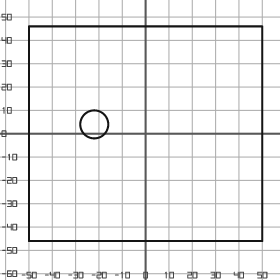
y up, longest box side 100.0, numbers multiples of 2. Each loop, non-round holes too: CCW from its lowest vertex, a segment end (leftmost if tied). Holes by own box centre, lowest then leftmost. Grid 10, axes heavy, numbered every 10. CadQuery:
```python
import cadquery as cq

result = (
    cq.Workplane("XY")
    .moveTo(-50.0, -46.0)
    .lineTo(50.0, -46.0)
    .lineTo(50.0, 46.0)
    .lineTo(-50.0, 46.0)
    .close()
    .moveTo(-22.0, 4.0)
    .circle(6.0)
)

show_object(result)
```